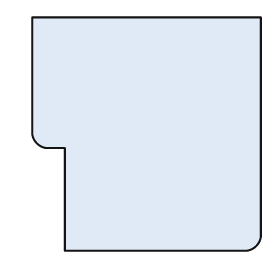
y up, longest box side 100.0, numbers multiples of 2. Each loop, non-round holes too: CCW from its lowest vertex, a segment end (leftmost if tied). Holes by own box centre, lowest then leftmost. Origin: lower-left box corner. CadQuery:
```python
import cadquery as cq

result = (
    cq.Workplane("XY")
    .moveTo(14.0, 0.0)
    .lineTo(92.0, 0.0)
    .threePointArc((96.0, 2.0), (98.0, 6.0))
    .lineTo(98.0, 100.0)
    .lineTo(0.0, 100.0)
    .lineTo(0.0, 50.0)
    .threePointArc((2.0, 46.0), (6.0, 44.0))
    .lineTo(14.0, 44.0)
    .close()
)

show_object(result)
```